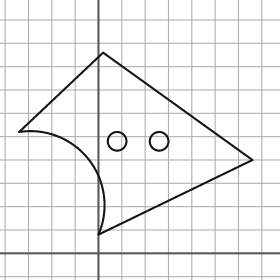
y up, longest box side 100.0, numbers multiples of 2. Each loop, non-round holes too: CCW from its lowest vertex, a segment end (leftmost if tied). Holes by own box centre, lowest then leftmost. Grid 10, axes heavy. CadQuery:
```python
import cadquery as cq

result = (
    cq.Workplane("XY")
    .moveTo(0.0, 8.0)
    .lineTo(66.0, 40.0)
    .lineTo(2.0, 86.0)
    .lineTo(-34.0, 52.0)
    .threePointArc((-4.0, 40.0), (0.0, 8.0))
    .close()
    .moveTo(8.0, 48.0)
    .circle(4.0)
    .moveTo(26.0, 48.0)
    .circle(4.0)
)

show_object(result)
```